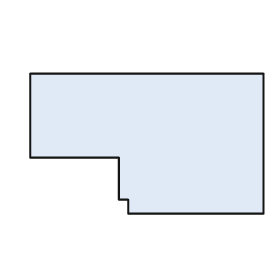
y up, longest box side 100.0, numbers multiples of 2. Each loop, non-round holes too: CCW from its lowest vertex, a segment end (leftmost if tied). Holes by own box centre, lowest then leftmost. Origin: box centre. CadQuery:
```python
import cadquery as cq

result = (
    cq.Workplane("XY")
    .moveTo(-8.0, -30.0)
    .lineTo(50.0, -30.0)
    .lineTo(50.0, 30.0)
    .lineTo(-50.0, 30.0)
    .lineTo(-50.0, -6.0)
    .lineTo(-12.0, -6.0)
    .lineTo(-12.0, -24.0)
    .lineTo(-8.0, -24.0)
    .close()
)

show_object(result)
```